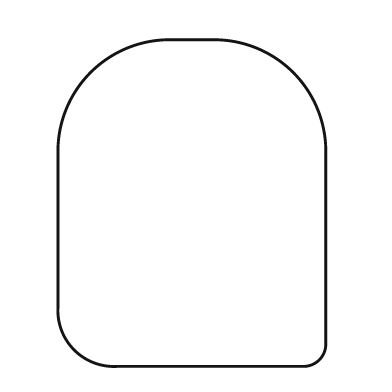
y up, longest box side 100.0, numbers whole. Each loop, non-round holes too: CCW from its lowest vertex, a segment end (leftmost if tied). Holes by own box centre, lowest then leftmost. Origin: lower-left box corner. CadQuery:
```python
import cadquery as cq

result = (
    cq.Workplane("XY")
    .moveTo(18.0, 0.0)
    .lineTo(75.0, 0.0)
    .threePointArc((80.0, 2.0), (82.0, 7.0))
    .lineTo(82.0, 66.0)
    .threePointArc((72.0, 90.0), (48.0, 100.0))
    .lineTo(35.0, 100.0)
    .threePointArc((10.0, 90.0), (0.0, 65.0))
    .lineTo(0.0, 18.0)
    .threePointArc((5.0, 5.0), (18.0, 0.0))
    .close()
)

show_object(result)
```